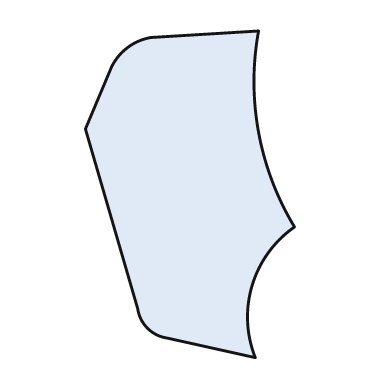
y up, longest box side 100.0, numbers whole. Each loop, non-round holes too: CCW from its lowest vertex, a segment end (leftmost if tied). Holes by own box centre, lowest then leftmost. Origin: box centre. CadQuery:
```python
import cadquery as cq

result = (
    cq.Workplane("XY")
    .moveTo(20.0, -50.0)
    .threePointArc((19.0, -28.0), (32.0, -10.0))
    .threePointArc((21.0, 19.0), (21.0, 50.0))
    .lineTo(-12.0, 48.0)
    .threePointArc((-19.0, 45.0), (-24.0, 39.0))
    .lineTo(-32.0, 20.0)
    .lineTo(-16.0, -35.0)
    .threePointArc((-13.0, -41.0), (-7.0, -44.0))
    .close()
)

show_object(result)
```